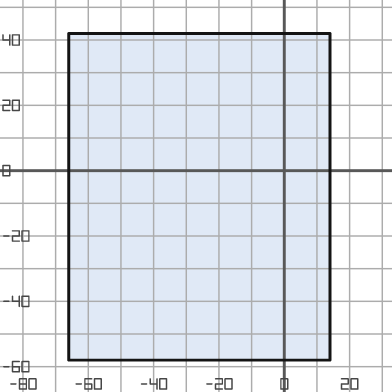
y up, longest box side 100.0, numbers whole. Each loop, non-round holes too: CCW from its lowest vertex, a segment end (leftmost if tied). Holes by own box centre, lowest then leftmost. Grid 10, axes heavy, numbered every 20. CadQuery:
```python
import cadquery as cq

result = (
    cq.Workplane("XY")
    .moveTo(-66.0, -58.0)
    .lineTo(14.0, -58.0)
    .lineTo(14.0, 42.0)
    .lineTo(-66.0, 42.0)
    .close()
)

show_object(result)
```